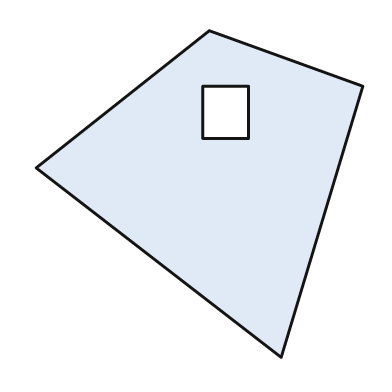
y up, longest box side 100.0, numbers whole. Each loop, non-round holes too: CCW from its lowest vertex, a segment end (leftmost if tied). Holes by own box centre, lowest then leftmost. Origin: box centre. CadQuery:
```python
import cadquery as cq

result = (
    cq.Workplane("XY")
    .moveTo(25.0, -50.0)
    .lineTo(50.0, 33.0)
    .lineTo(3.0, 50.0)
    .lineTo(-50.0, 8.0)
    .close()
    .moveTo(1.0, 17.0)
    .lineTo(15.0, 17.0)
    .lineTo(15.0, 33.0)
    .lineTo(1.0, 33.0)
    .close()
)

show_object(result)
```